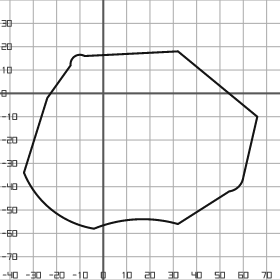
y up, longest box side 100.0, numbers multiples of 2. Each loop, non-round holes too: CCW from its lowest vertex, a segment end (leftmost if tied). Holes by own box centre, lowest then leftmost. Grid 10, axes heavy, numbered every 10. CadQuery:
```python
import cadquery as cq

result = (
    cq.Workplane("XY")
    .moveTo(-4.0, -58.0)
    .threePointArc((14.0, -54.0), (32.0, -56.0))
    .lineTo(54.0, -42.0)
    .threePointArc((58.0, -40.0), (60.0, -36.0))
    .lineTo(66.0, -10.0)
    .lineTo(32.0, 18.0)
    .lineTo(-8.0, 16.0)
    .threePointArc((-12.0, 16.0), (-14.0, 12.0))
    .lineTo(-24.0, -2.0)
    .lineTo(-34.0, -34.0)
    .threePointArc((-22.0, -50.0), (-4.0, -58.0))
    .close()
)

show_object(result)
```